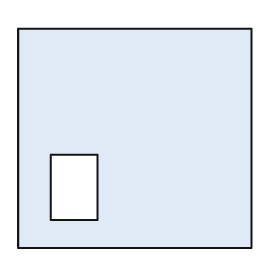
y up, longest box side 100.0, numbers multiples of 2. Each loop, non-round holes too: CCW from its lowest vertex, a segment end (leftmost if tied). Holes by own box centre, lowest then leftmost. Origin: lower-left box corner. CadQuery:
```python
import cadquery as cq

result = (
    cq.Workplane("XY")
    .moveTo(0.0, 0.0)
    .lineTo(100.0, 0.0)
    .lineTo(100.0, 94.0)
    .lineTo(0.0, 94.0)
    .close()
    .moveTo(14.0, 12.0)
    .lineTo(34.0, 12.0)
    .lineTo(34.0, 40.0)
    .lineTo(14.0, 40.0)
    .close()
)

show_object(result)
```